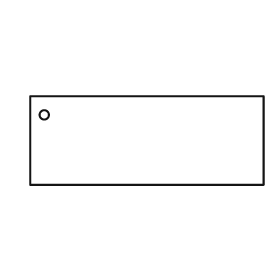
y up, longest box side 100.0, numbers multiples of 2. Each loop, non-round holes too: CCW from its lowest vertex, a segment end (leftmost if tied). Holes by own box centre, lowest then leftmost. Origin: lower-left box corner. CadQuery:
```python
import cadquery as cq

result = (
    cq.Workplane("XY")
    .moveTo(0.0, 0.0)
    .lineTo(100.0, 0.0)
    .lineTo(100.0, 38.0)
    .lineTo(0.0, 38.0)
    .close()
    .moveTo(6.0, 30.0)
    .circle(2.0)
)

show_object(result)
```